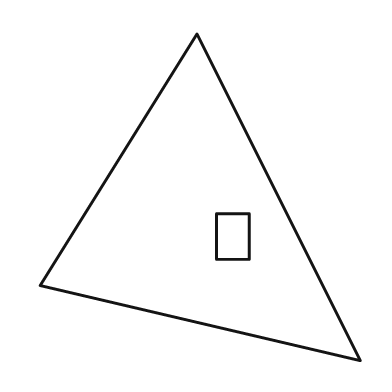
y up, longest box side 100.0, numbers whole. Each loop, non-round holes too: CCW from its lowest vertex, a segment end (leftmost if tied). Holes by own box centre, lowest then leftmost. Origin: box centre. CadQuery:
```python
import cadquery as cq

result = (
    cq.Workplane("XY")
    .moveTo(49.0, -50.0)
    .lineTo(-1.0, 50.0)
    .lineTo(-49.0, -27.0)
    .close()
    .moveTo(5.0, -19.0)
    .lineTo(15.0, -19.0)
    .lineTo(15.0, -5.0)
    .lineTo(5.0, -5.0)
    .close()
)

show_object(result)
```